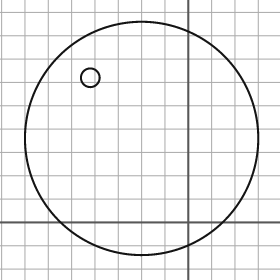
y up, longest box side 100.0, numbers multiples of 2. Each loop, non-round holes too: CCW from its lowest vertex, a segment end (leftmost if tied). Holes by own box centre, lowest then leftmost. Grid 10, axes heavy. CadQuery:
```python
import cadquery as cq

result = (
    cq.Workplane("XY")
    .moveTo(-20.0, 36.0)
    .circle(50.0)
    .moveTo(-42.0, 62.0)
    .circle(4.0)
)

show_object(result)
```